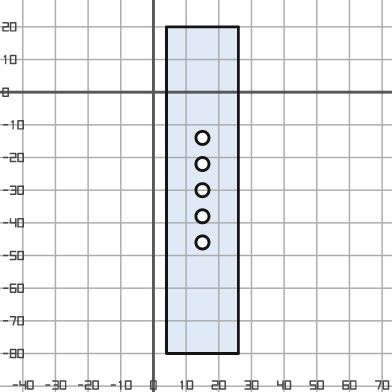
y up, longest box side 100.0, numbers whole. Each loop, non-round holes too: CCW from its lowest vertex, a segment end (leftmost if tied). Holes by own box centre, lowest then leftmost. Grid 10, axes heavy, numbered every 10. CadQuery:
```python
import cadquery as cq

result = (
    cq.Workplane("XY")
    .moveTo(4.0, -80.0)
    .lineTo(26.0, -80.0)
    .lineTo(26.0, 20.0)
    .lineTo(4.0, 20.0)
    .close()
    .moveTo(15.0, -46.0)
    .circle(2.0)
    .moveTo(15.0, -38.0)
    .circle(2.0)
    .moveTo(15.0, -30.0)
    .circle(2.0)
    .moveTo(15.0, -22.0)
    .circle(2.0)
    .moveTo(15.0, -14.0)
    .circle(2.0)
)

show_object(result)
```